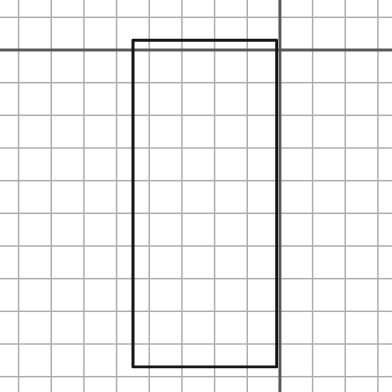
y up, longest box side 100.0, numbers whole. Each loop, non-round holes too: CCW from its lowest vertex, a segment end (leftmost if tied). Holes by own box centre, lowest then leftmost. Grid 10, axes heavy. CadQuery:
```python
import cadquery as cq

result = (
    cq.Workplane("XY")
    .moveTo(-45.0, -97.0)
    .lineTo(-1.0, -97.0)
    .lineTo(-1.0, 3.0)
    .lineTo(-45.0, 3.0)
    .close()
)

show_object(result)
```